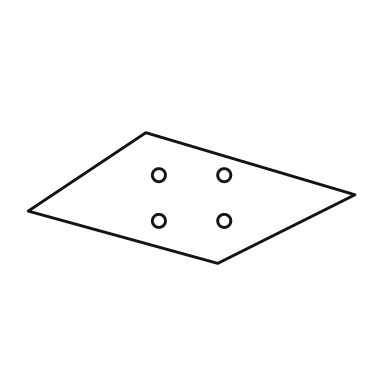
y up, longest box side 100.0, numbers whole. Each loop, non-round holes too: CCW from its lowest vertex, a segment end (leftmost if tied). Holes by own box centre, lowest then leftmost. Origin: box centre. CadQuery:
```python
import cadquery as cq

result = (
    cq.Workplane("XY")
    .moveTo(8.0, -20.0)
    .lineTo(50.0, 1.0)
    .lineTo(-14.0, 20.0)
    .lineTo(-50.0, -4.0)
    .close()
    .moveTo(-10.0, -7.0)
    .circle(2.0)
    .moveTo(10.0, -7.0)
    .circle(2.0)
    .moveTo(-10.0, 7.0)
    .circle(2.0)
    .moveTo(10.0, 7.0)
    .circle(2.0)
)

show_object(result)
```